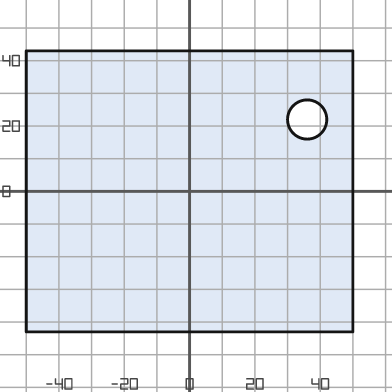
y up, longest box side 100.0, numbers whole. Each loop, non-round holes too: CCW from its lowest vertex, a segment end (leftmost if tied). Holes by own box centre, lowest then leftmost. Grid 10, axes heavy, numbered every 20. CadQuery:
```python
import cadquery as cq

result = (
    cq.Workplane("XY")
    .moveTo(-50.0, -43.0)
    .lineTo(50.0, -43.0)
    .lineTo(50.0, 43.0)
    .lineTo(-50.0, 43.0)
    .close()
    .moveTo(36.0, 22.0)
    .circle(6.0)
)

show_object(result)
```